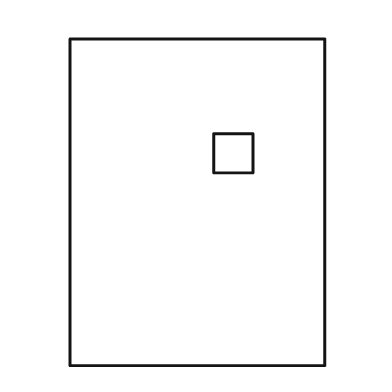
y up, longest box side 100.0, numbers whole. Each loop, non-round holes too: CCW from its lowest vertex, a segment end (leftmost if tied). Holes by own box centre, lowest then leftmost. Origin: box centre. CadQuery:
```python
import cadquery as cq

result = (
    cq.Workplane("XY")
    .moveTo(-39.0, -50.0)
    .lineTo(39.0, -50.0)
    .lineTo(39.0, 50.0)
    .lineTo(-39.0, 50.0)
    .close()
    .moveTo(5.0, 9.0)
    .lineTo(17.0, 9.0)
    .lineTo(17.0, 21.0)
    .lineTo(5.0, 21.0)
    .close()
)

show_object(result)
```